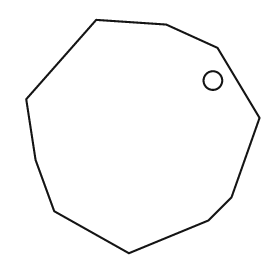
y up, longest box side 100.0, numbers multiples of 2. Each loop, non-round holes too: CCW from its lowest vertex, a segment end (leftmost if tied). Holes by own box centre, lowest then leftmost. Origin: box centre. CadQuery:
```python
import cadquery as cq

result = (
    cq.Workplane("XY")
    .moveTo(-6.0, -50.0)
    .lineTo(28.0, -36.0)
    .lineTo(38.0, -26.0)
    .lineTo(50.0, 8.0)
    .lineTo(32.0, 38.0)
    .lineTo(10.0, 48.0)
    .lineTo(-20.0, 50.0)
    .lineTo(-50.0, 16.0)
    .lineTo(-46.0, -10.0)
    .lineTo(-38.0, -32.0)
    .close()
    .moveTo(30.0, 24.0)
    .circle(4.0)
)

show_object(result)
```